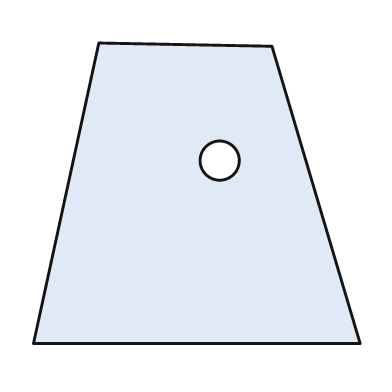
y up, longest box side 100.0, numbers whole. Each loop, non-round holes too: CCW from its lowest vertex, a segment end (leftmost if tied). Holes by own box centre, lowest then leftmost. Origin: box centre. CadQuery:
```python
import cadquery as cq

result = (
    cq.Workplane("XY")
    .moveTo(-50.0, -46.0)
    .lineTo(50.0, -46.0)
    .lineTo(23.0, 45.0)
    .lineTo(-30.0, 46.0)
    .close()
    .moveTo(7.0, 10.0)
    .circle(6.0)
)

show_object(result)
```